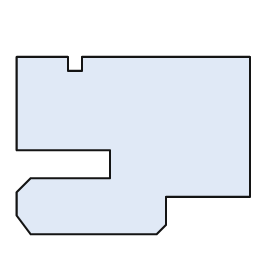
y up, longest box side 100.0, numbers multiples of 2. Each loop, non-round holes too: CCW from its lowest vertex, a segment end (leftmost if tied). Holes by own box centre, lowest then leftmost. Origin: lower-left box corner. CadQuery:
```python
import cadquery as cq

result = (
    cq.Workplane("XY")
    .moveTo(6.0, 0.0)
    .lineTo(60.0, 0.0)
    .lineTo(64.0, 4.0)
    .lineTo(64.0, 16.0)
    .lineTo(100.0, 16.0)
    .lineTo(100.0, 76.0)
    .lineTo(28.0, 76.0)
    .lineTo(28.0, 70.0)
    .lineTo(22.0, 70.0)
    .lineTo(22.0, 76.0)
    .lineTo(0.0, 76.0)
    .lineTo(0.0, 36.0)
    .lineTo(40.0, 36.0)
    .lineTo(40.0, 24.0)
    .lineTo(6.0, 24.0)
    .lineTo(0.0, 18.0)
    .lineTo(0.0, 8.0)
    .close()
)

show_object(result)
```